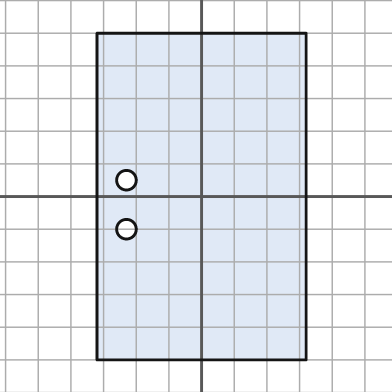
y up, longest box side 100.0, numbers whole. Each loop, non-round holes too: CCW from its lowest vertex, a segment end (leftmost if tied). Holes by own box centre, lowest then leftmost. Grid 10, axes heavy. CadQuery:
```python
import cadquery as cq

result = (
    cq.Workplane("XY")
    .moveTo(-32.0, -50.0)
    .lineTo(32.0, -50.0)
    .lineTo(32.0, 50.0)
    .lineTo(-32.0, 50.0)
    .close()
    .moveTo(-23.0, -10.0)
    .circle(3.0)
    .moveTo(-23.0, 5.0)
    .circle(3.0)
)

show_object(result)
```